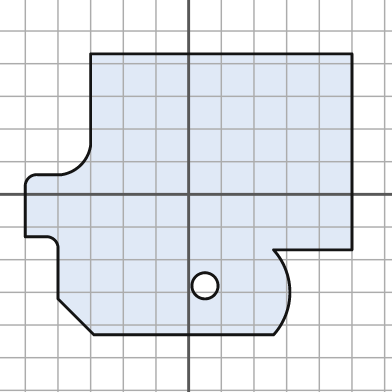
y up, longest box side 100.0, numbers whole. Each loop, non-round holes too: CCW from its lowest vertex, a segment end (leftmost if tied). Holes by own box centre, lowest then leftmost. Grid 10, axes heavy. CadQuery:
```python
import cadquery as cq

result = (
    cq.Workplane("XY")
    .moveTo(-29.0, -43.0)
    .lineTo(26.0, -43.0)
    .threePointArc((31.0, -30.0), (26.0, -17.0))
    .lineTo(50.0, -17.0)
    .lineTo(50.0, 43.0)
    .lineTo(-30.0, 43.0)
    .lineTo(-30.0, 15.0)
    .threePointArc((-33.0, 9.0), (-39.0, 6.0))
    .lineTo(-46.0, 6.0)
    .threePointArc((-49.0, 5.0), (-50.0, 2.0))
    .lineTo(-50.0, -13.0)
    .lineTo(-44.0, -13.0)
    .threePointArc((-41.0, -14.0), (-40.0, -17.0))
    .lineTo(-40.0, -32.0)
    .close()
    .moveTo(5.0, -28.0)
    .circle(4.0)
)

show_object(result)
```